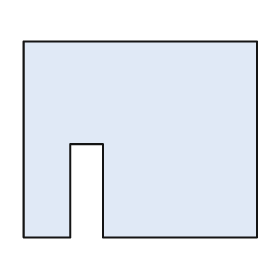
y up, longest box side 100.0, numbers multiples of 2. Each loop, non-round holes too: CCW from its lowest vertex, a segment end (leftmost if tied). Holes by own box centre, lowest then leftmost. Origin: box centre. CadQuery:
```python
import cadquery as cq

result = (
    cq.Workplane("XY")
    .moveTo(-50.0, -42.0)
    .lineTo(-30.0, -42.0)
    .lineTo(-30.0, -2.0)
    .lineTo(-16.0, -2.0)
    .lineTo(-16.0, -42.0)
    .lineTo(50.0, -42.0)
    .lineTo(50.0, 42.0)
    .lineTo(-50.0, 42.0)
    .close()
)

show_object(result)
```